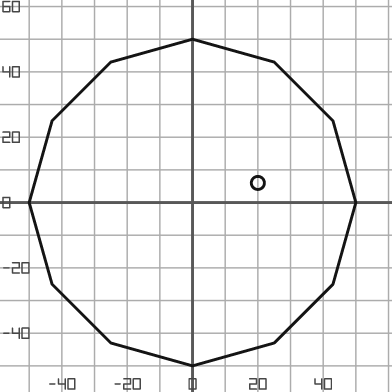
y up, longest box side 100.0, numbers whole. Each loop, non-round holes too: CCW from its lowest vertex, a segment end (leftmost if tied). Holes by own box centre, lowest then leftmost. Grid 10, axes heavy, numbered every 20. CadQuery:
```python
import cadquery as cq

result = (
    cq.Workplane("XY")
    .moveTo(0.0, -50.0)
    .lineTo(25.0, -43.0)
    .lineTo(43.0, -25.0)
    .lineTo(50.0, 0.0)
    .lineTo(43.0, 25.0)
    .lineTo(25.0, 43.0)
    .lineTo(0.0, 50.0)
    .lineTo(-25.0, 43.0)
    .lineTo(-43.0, 25.0)
    .lineTo(-50.0, 0.0)
    .lineTo(-43.0, -25.0)
    .lineTo(-25.0, -43.0)
    .close()
    .moveTo(20.0, 6.0)
    .circle(2.0)
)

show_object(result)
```